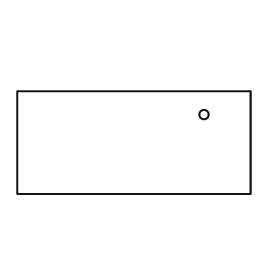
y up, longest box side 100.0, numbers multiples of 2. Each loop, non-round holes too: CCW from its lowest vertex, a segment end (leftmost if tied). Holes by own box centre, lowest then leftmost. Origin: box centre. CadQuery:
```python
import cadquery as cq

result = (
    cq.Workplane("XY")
    .moveTo(-50.0, -22.0)
    .lineTo(50.0, -22.0)
    .lineTo(50.0, 22.0)
    .lineTo(-50.0, 22.0)
    .close()
    .moveTo(30.0, 12.0)
    .circle(2.0)
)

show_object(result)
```